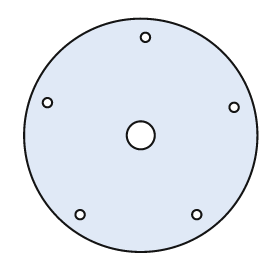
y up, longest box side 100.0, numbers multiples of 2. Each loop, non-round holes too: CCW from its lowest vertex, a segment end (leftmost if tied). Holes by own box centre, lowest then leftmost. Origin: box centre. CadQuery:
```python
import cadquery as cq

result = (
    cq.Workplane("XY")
    .moveTo(0.0, 0.0)
    .circle(50.0)
    .moveTo(-26.0, -34.0)
    .circle(2.0)
    .moveTo(24.0, -34.0)
    .circle(2.0)
    .moveTo(0.0, 0.0)
    .circle(6.0)
    .moveTo(40.0, 12.0)
    .circle(2.0)
    .moveTo(-40.0, 14.0)
    .circle(2.0)
    .moveTo(2.0, 42.0)
    .circle(2.0)
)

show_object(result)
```